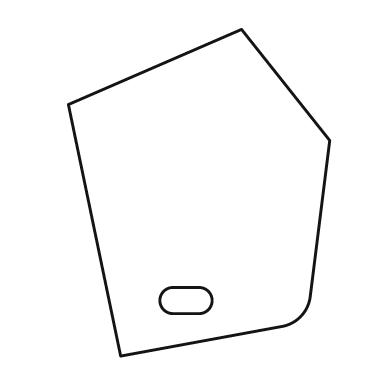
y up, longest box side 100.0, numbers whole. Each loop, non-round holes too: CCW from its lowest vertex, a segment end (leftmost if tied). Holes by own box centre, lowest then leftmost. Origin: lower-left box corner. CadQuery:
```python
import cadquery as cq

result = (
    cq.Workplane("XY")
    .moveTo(16.0, 0.0)
    .lineTo(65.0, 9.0)
    .threePointArc((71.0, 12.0), (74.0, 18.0))
    .lineTo(80.0, 66.0)
    .lineTo(53.0, 100.0)
    .lineTo(0.0, 77.0)
    .close()
    .moveTo(32.0, 13.0)
    .lineTo(40.0, 13.0)
    .threePointArc((44.0, 17.0), (40.0, 21.0))
    .lineTo(32.0, 21.0)
    .threePointArc((28.0, 17.0), (32.0, 13.0))
    .close()
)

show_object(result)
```